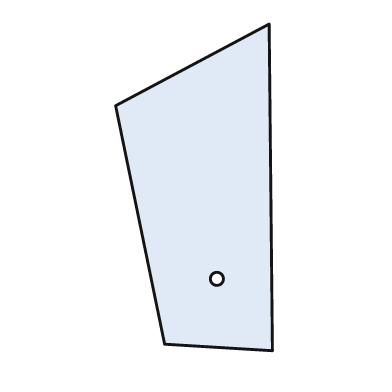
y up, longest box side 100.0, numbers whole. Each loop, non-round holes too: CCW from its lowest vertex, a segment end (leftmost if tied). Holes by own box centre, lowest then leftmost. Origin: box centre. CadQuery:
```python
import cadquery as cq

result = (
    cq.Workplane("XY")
    .moveTo(24.0, -50.0)
    .lineTo(23.0, 50.0)
    .lineTo(-24.0, 25.0)
    .lineTo(-9.0, -48.0)
    .close()
    .moveTo(7.0, -28.0)
    .circle(2.0)
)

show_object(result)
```